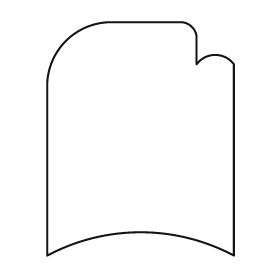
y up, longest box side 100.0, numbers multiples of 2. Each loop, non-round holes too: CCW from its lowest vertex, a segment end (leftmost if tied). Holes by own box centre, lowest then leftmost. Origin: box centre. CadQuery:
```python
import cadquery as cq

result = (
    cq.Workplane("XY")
    .moveTo(-40.0, -50.0)
    .threePointArc((0.0, -40.0), (40.0, -50.0))
    .lineTo(40.0, 32.0)
    .threePointArc((32.0, 36.0), (24.0, 32.0))
    .lineTo(24.0, 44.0)
    .threePointArc((22.0, 48.0), (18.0, 50.0))
    .lineTo(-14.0, 50.0)
    .threePointArc((-32.0, 42.0), (-40.0, 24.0))
    .close()
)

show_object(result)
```